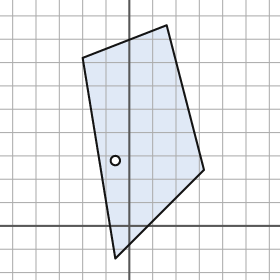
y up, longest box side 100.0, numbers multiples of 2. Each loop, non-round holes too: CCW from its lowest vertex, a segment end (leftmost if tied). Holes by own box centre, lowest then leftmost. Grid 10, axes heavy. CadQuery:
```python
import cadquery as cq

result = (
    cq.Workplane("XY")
    .moveTo(-6.0, -14.0)
    .lineTo(32.0, 24.0)
    .lineTo(16.0, 86.0)
    .lineTo(-20.0, 72.0)
    .close()
    .moveTo(-6.0, 28.0)
    .circle(2.0)
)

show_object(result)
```